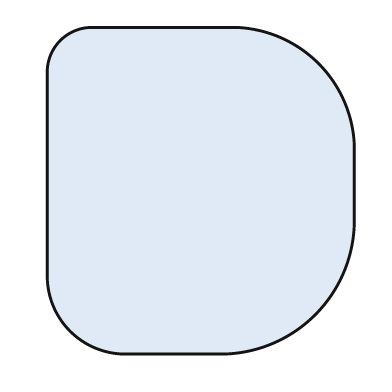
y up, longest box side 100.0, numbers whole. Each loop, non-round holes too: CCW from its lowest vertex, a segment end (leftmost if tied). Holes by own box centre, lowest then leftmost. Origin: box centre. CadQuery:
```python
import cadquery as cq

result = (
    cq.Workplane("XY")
    .moveTo(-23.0, -50.0)
    .lineTo(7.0, -50.0)
    .threePointArc((35.0, -38.0), (47.0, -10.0))
    .lineTo(47.0, 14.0)
    .threePointArc((36.0, 39.0), (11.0, 50.0))
    .lineTo(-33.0, 50.0)
    .threePointArc((-43.0, 46.0), (-47.0, 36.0))
    .lineTo(-47.0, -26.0)
    .threePointArc((-40.0, -43.0), (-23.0, -50.0))
    .close()
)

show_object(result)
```